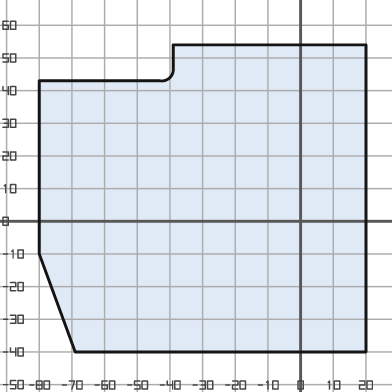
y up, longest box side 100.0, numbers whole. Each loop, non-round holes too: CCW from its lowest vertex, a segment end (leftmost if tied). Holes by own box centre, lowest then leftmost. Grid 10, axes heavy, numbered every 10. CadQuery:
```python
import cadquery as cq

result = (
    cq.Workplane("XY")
    .moveTo(-69.0, -40.0)
    .lineTo(20.0, -40.0)
    .lineTo(20.0, 54.0)
    .lineTo(-39.0, 54.0)
    .lineTo(-39.0, 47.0)
    .threePointArc((-40.0, 44.0), (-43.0, 43.0))
    .lineTo(-80.0, 43.0)
    .lineTo(-80.0, -10.0)
    .close()
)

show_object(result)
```